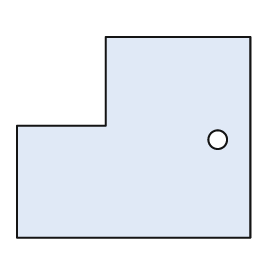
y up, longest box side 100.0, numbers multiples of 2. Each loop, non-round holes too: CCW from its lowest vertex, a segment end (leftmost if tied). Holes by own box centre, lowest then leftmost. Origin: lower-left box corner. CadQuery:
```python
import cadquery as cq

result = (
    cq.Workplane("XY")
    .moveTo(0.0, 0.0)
    .lineTo(100.0, 0.0)
    .lineTo(100.0, 86.0)
    .lineTo(38.0, 86.0)
    .lineTo(38.0, 48.0)
    .lineTo(0.0, 48.0)
    .close()
    .moveTo(86.0, 42.0)
    .circle(4.0)
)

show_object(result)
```